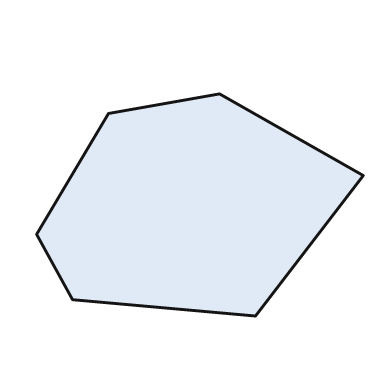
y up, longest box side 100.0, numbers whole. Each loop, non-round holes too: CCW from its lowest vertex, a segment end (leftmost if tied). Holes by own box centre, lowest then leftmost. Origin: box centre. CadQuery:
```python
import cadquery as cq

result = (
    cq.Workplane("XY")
    .moveTo(17.0, -34.0)
    .lineTo(50.0, 9.0)
    .lineTo(6.0, 34.0)
    .lineTo(-28.0, 28.0)
    .lineTo(-50.0, -9.0)
    .lineTo(-39.0, -29.0)
    .close()
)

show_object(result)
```